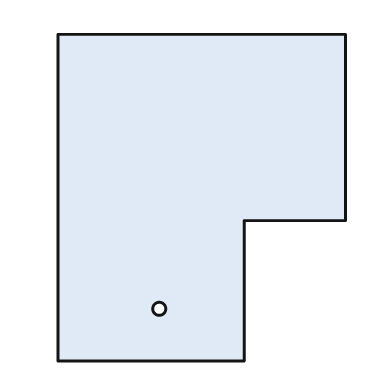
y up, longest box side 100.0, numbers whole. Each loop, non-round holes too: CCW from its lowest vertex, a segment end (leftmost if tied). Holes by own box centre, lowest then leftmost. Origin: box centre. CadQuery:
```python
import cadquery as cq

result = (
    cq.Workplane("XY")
    .moveTo(-44.0, -50.0)
    .lineTo(13.0, -50.0)
    .lineTo(13.0, -7.0)
    .lineTo(44.0, -7.0)
    .lineTo(44.0, 50.0)
    .lineTo(-44.0, 50.0)
    .close()
    .moveTo(-13.0, -34.0)
    .circle(2.0)
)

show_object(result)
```